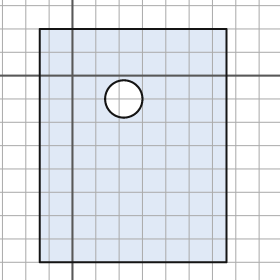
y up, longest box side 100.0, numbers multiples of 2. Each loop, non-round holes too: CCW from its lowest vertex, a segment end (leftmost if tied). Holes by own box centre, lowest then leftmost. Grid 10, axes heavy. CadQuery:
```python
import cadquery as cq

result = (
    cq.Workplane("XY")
    .moveTo(-14.0, -80.0)
    .lineTo(66.0, -80.0)
    .lineTo(66.0, 20.0)
    .lineTo(-14.0, 20.0)
    .close()
    .moveTo(22.0, -10.0)
    .circle(8.0)
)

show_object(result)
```